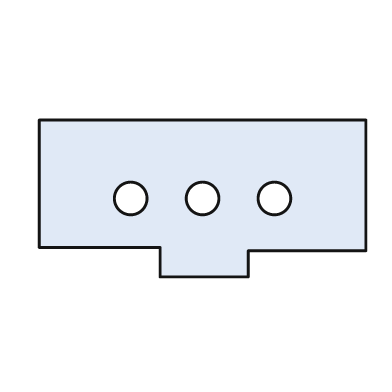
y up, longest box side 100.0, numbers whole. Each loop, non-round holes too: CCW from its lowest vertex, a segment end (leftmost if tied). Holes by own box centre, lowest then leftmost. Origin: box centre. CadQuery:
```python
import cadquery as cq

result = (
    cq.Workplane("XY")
    .moveTo(-13.0, -24.0)
    .lineTo(14.0, -24.0)
    .lineTo(14.0, -16.0)
    .lineTo(50.0, -16.0)
    .lineTo(50.0, 24.0)
    .lineTo(-50.0, 24.0)
    .lineTo(-50.0, -15.0)
    .lineTo(-13.0, -15.0)
    .close()
    .moveTo(-22.0, 0.0)
    .circle(5.0)
    .moveTo(0.0, 0.0)
    .circle(5.0)
    .moveTo(22.0, 0.0)
    .circle(5.0)
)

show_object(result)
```